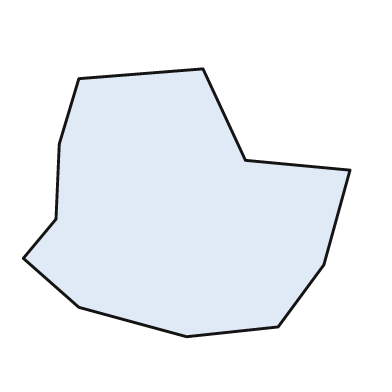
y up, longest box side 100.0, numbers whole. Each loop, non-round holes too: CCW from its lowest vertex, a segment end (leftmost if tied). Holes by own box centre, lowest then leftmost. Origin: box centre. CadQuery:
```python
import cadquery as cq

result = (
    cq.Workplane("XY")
    .moveTo(0.0, -41.0)
    .lineTo(28.0, -38.0)
    .lineTo(42.0, -19.0)
    .lineTo(50.0, 10.0)
    .lineTo(18.0, 13.0)
    .lineTo(5.0, 41.0)
    .lineTo(-33.0, 38.0)
    .lineTo(-39.0, 18.0)
    .lineTo(-40.0, -5.0)
    .lineTo(-50.0, -17.0)
    .lineTo(-33.0, -32.0)
    .close()
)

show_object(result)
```